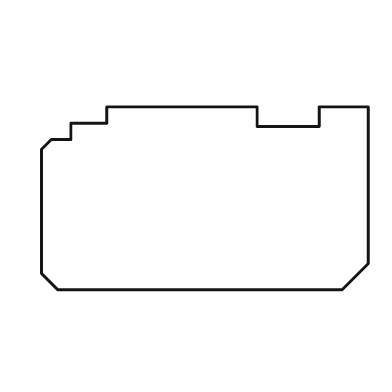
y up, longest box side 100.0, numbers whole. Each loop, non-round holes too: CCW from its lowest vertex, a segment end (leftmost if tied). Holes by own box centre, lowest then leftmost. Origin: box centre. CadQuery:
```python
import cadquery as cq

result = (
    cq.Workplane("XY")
    .moveTo(-45.0, -28.0)
    .lineTo(42.0, -28.0)
    .lineTo(50.0, -20.0)
    .lineTo(50.0, 28.0)
    .lineTo(35.0, 28.0)
    .lineTo(35.0, 22.0)
    .lineTo(16.0, 22.0)
    .lineTo(16.0, 28.0)
    .lineTo(-30.0, 28.0)
    .lineTo(-30.0, 23.0)
    .lineTo(-41.0, 23.0)
    .lineTo(-41.0, 18.0)
    .lineTo(-47.0, 18.0)
    .lineTo(-50.0, 15.0)
    .lineTo(-50.0, -23.0)
    .close()
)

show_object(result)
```